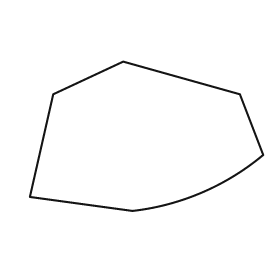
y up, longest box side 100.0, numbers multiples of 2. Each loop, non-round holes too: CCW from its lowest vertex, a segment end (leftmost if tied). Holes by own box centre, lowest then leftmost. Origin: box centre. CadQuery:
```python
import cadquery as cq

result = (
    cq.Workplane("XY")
    .moveTo(-6.0, -32.0)
    .threePointArc((24.0, -24.0), (50.0, -8.0))
    .lineTo(40.0, 18.0)
    .lineTo(-10.0, 32.0)
    .lineTo(-40.0, 18.0)
    .lineTo(-50.0, -26.0)
    .close()
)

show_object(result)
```